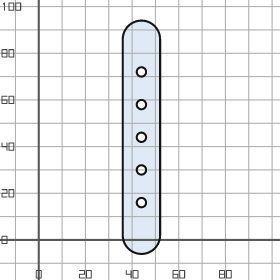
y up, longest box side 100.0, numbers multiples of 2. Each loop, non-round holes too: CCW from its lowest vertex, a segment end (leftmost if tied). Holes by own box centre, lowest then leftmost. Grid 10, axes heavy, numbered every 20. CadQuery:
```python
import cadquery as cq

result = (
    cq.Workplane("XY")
    .moveTo(36.0, 2.0)
    .threePointArc((44.0, -6.0), (52.0, 2.0))
    .lineTo(52.0, 86.0)
    .threePointArc((44.0, 94.0), (36.0, 86.0))
    .close()
    .moveTo(44.0, 16.0)
    .circle(2.0)
    .moveTo(44.0, 30.0)
    .circle(2.0)
    .moveTo(44.0, 44.0)
    .circle(2.0)
    .moveTo(44.0, 58.0)
    .circle(2.0)
    .moveTo(44.0, 72.0)
    .circle(2.0)
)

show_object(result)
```